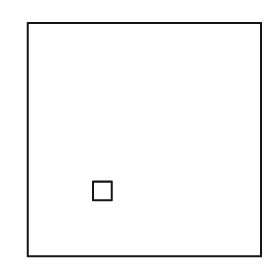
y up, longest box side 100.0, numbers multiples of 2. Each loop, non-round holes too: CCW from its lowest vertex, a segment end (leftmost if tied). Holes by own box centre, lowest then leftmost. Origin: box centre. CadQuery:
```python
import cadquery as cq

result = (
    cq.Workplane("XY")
    .moveTo(-50.0, -50.0)
    .lineTo(50.0, -50.0)
    .lineTo(50.0, 50.0)
    .lineTo(-50.0, 50.0)
    .close()
    .moveTo(-22.0, -26.0)
    .lineTo(-14.0, -26.0)
    .lineTo(-14.0, -18.0)
    .lineTo(-22.0, -18.0)
    .close()
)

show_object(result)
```